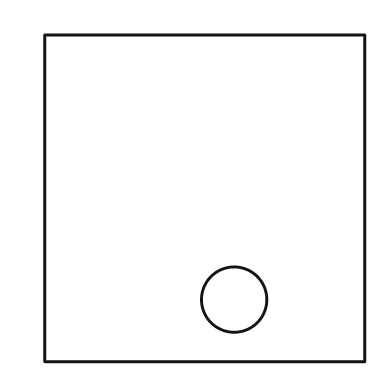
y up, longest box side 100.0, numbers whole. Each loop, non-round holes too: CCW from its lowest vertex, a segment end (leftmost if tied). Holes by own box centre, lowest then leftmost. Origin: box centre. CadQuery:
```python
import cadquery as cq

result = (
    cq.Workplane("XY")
    .moveTo(-49.0, -50.0)
    .lineTo(49.0, -50.0)
    .lineTo(49.0, 50.0)
    .lineTo(-49.0, 50.0)
    .close()
    .moveTo(9.0, -31.0)
    .circle(10.0)
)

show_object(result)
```